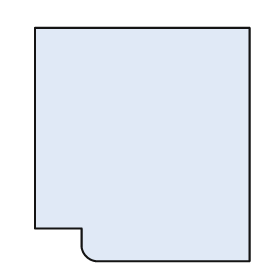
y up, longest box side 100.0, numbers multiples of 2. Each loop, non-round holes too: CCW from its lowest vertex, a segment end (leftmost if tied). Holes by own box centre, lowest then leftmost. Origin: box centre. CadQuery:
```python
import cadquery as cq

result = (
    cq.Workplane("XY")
    .moveTo(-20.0, -50.0)
    .lineTo(46.0, -50.0)
    .lineTo(46.0, 50.0)
    .lineTo(-46.0, 50.0)
    .lineTo(-46.0, -36.0)
    .lineTo(-26.0, -36.0)
    .lineTo(-26.0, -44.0)
    .threePointArc((-24.0, -48.0), (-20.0, -50.0))
    .close()
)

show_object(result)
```